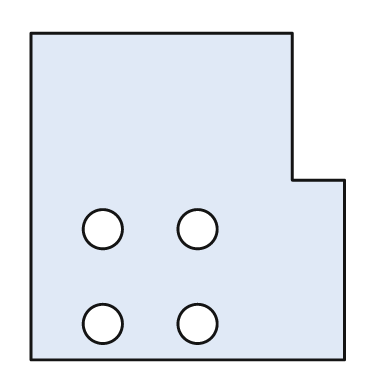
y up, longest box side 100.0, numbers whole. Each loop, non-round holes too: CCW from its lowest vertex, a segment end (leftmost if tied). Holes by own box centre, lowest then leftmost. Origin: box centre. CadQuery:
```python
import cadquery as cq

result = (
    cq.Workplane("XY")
    .moveTo(-48.0, -50.0)
    .lineTo(48.0, -50.0)
    .lineTo(48.0, 5.0)
    .lineTo(32.0, 5.0)
    .lineTo(32.0, 50.0)
    .lineTo(-48.0, 50.0)
    .close()
    .moveTo(-26.0, -39.0)
    .circle(6.0)
    .moveTo(3.0, -39.0)
    .circle(6.0)
    .moveTo(-26.0, -10.0)
    .circle(6.0)
    .moveTo(3.0, -10.0)
    .circle(6.0)
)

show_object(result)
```